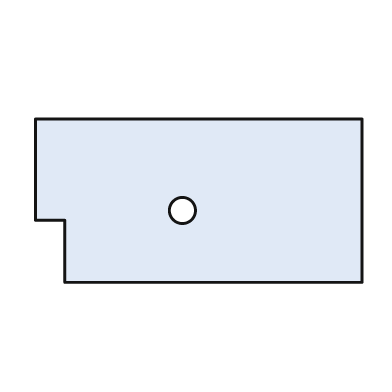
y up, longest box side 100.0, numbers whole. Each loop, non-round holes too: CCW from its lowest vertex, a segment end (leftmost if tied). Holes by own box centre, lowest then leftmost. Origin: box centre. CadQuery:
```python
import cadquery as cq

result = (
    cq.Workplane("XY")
    .moveTo(-41.0, -25.0)
    .lineTo(50.0, -25.0)
    .lineTo(50.0, 25.0)
    .lineTo(-50.0, 25.0)
    .lineTo(-50.0, -6.0)
    .lineTo(-41.0, -6.0)
    .close()
    .moveTo(-5.0, -3.0)
    .circle(4.0)
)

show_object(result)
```